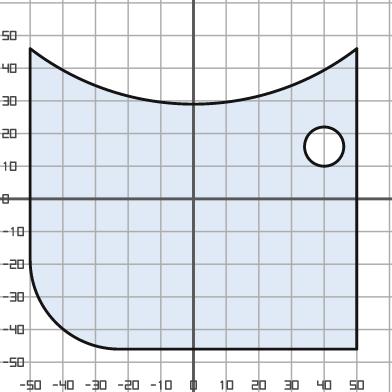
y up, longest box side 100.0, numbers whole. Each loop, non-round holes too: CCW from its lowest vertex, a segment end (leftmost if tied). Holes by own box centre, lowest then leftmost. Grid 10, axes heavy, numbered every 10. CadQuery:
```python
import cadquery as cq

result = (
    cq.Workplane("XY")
    .moveTo(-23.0, -46.0)
    .lineTo(50.0, -46.0)
    .lineTo(50.0, 46.0)
    .threePointArc((0.0, 29.0), (-50.0, 46.0))
    .lineTo(-50.0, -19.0)
    .threePointArc((-42.0, -38.0), (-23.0, -46.0))
    .close()
    .moveTo(40.0, 16.0)
    .circle(6.0)
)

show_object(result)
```